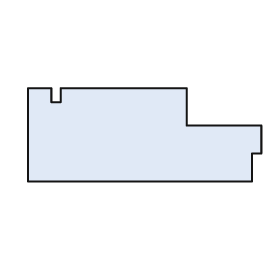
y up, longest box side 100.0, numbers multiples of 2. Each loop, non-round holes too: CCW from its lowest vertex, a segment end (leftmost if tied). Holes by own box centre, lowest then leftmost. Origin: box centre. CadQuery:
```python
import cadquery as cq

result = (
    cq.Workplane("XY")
    .moveTo(-50.0, -20.0)
    .lineTo(46.0, -20.0)
    .lineTo(46.0, -8.0)
    .lineTo(50.0, -8.0)
    .lineTo(50.0, 4.0)
    .lineTo(18.0, 4.0)
    .lineTo(18.0, 20.0)
    .lineTo(-36.0, 20.0)
    .lineTo(-36.0, 14.0)
    .lineTo(-40.0, 14.0)
    .lineTo(-40.0, 20.0)
    .lineTo(-50.0, 20.0)
    .close()
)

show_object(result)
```